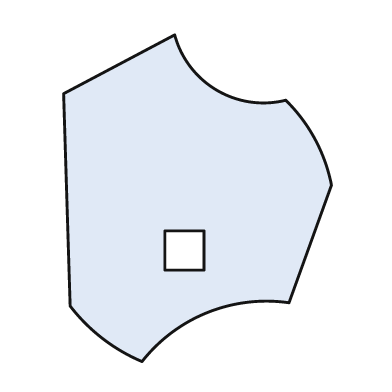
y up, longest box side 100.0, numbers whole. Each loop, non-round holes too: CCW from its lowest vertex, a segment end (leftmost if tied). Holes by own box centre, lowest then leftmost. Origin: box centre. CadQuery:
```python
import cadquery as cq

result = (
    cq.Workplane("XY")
    .moveTo(-17.0, -50.0)
    .threePointArc((3.0, -35.0), (28.0, -32.0))
    .lineTo(41.0, 4.0)
    .threePointArc((36.0, 18.0), (27.0, 30.0))
    .threePointArc((6.0, 33.0), (-7.0, 50.0))
    .lineTo(-41.0, 32.0)
    .lineTo(-39.0, -33.0)
    .threePointArc((-29.0, -43.0), (-17.0, -50.0))
    .close()
    .moveTo(-10.0, -22.0)
    .lineTo(2.0, -22.0)
    .lineTo(2.0, -10.0)
    .lineTo(-10.0, -10.0)
    .close()
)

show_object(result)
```